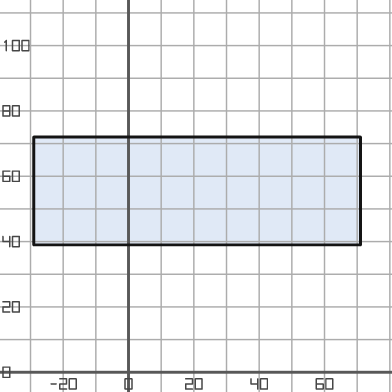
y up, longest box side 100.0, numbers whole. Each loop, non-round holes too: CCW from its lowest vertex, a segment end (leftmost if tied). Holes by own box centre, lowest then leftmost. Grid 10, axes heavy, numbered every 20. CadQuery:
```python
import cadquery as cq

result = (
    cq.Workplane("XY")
    .moveTo(-29.0, 39.0)
    .lineTo(71.0, 39.0)
    .lineTo(71.0, 72.0)
    .lineTo(-29.0, 72.0)
    .close()
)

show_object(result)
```